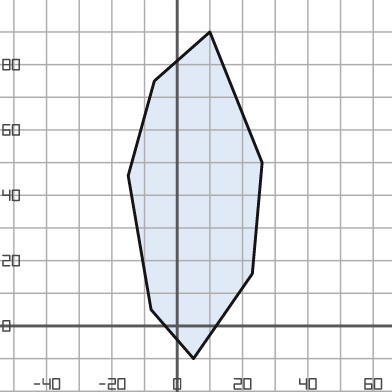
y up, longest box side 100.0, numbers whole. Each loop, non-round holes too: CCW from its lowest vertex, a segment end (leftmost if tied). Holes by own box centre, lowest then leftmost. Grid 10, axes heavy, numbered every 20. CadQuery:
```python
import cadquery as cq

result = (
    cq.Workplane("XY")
    .moveTo(5.0, -10.0)
    .lineTo(23.0, 16.0)
    .lineTo(26.0, 50.0)
    .lineTo(10.0, 90.0)
    .lineTo(-7.0, 75.0)
    .lineTo(-15.0, 46.0)
    .lineTo(-8.0, 5.0)
    .close()
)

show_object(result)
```